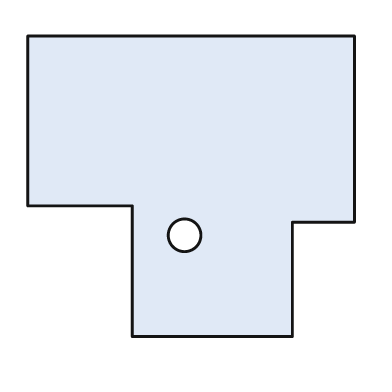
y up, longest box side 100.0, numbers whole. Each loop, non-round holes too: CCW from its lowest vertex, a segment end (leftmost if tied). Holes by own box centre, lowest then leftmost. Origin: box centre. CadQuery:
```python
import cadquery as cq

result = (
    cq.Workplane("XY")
    .moveTo(-18.0, -46.0)
    .lineTo(31.0, -46.0)
    .lineTo(31.0, -11.0)
    .lineTo(50.0, -11.0)
    .lineTo(50.0, 46.0)
    .lineTo(-50.0, 46.0)
    .lineTo(-50.0, -6.0)
    .lineTo(-18.0, -6.0)
    .close()
    .moveTo(-2.0, -15.0)
    .circle(5.0)
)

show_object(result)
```